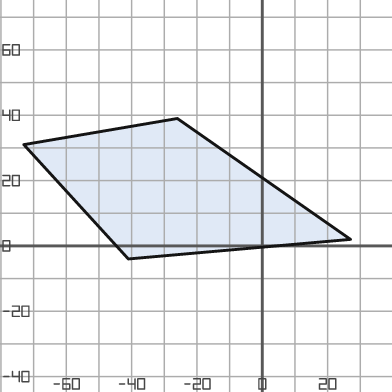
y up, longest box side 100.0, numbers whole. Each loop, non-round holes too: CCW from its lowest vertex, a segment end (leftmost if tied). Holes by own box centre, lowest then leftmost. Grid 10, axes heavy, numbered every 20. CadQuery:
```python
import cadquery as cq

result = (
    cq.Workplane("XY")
    .moveTo(-41.0, -4.0)
    .lineTo(27.0, 2.0)
    .lineTo(-26.0, 39.0)
    .lineTo(-73.0, 31.0)
    .close()
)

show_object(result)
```